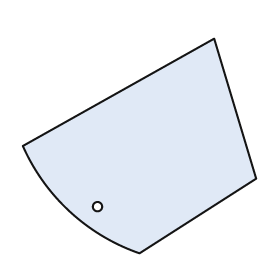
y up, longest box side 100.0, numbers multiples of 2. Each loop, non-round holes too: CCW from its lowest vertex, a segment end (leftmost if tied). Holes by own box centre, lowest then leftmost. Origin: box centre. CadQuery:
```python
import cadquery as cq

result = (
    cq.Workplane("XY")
    .moveTo(0.0, -46.0)
    .lineTo(50.0, -14.0)
    .lineTo(32.0, 46.0)
    .lineTo(-50.0, 0.0)
    .threePointArc((-30.0, -28.0), (0.0, -46.0))
    .close()
    .moveTo(-18.0, -26.0)
    .circle(2.0)
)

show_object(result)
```